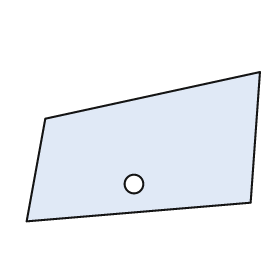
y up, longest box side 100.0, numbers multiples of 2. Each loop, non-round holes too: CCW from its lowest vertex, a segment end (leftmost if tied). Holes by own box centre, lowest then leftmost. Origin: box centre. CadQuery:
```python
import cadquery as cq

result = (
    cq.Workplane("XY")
    .moveTo(-50.0, -32.0)
    .lineTo(46.0, -24.0)
    .lineTo(50.0, 32.0)
    .lineTo(-42.0, 12.0)
    .close()
    .moveTo(-4.0, -16.0)
    .circle(4.0)
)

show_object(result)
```